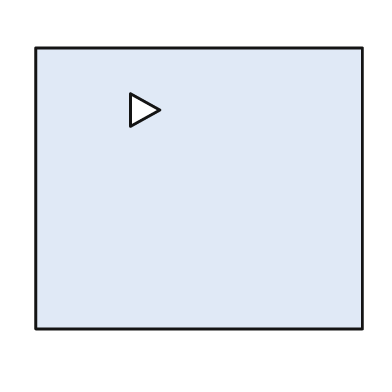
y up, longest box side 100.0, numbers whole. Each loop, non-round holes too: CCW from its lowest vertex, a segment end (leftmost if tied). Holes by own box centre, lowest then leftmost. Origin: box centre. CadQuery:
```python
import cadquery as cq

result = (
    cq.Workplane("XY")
    .moveTo(-50.0, -43.0)
    .lineTo(50.0, -43.0)
    .lineTo(50.0, 43.0)
    .lineTo(-50.0, 43.0)
    .close()
    .moveTo(-21.0, 19.0)
    .lineTo(-12.0, 24.0)
    .lineTo(-21.0, 29.0)
    .close()
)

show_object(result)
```